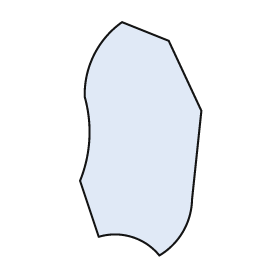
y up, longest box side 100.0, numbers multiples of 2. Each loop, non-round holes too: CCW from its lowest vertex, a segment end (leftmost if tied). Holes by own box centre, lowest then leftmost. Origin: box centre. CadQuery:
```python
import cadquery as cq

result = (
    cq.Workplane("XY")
    .moveTo(8.0, -50.0)
    .threePointArc((18.0, -40.0), (22.0, -26.0))
    .lineTo(26.0, 12.0)
    .lineTo(12.0, 42.0)
    .lineTo(-8.0, 50.0)
    .threePointArc((-20.0, 36.0), (-24.0, 18.0))
    .threePointArc((-22.0, 0.0), (-26.0, -18.0))
    .lineTo(-18.0, -42.0)
    .threePointArc((-4.0, -42.0), (8.0, -50.0))
    .close()
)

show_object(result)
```